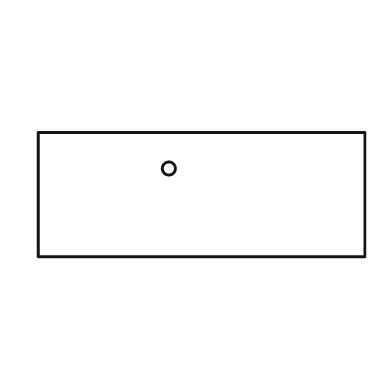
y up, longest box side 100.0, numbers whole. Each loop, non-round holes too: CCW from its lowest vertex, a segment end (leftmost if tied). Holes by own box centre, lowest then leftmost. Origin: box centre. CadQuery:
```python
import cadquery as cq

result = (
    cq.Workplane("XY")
    .moveTo(-50.0, -19.0)
    .lineTo(50.0, -19.0)
    .lineTo(50.0, 19.0)
    .lineTo(-50.0, 19.0)
    .close()
    .moveTo(-10.0, 8.0)
    .circle(2.0)
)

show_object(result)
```